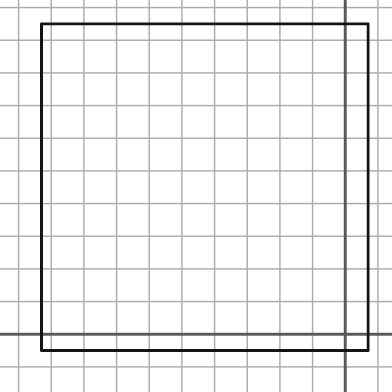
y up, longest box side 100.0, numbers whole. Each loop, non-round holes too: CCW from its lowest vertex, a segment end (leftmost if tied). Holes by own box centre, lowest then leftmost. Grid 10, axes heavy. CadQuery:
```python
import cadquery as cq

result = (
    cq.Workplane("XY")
    .moveTo(-93.0, -5.0)
    .lineTo(7.0, -5.0)
    .lineTo(7.0, 95.0)
    .lineTo(-93.0, 95.0)
    .close()
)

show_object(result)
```